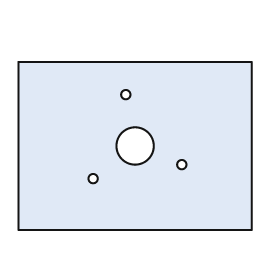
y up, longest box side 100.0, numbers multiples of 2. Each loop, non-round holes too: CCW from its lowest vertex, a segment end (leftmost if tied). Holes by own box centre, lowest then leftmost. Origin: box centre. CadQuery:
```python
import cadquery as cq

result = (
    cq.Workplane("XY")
    .moveTo(-50.0, -36.0)
    .lineTo(50.0, -36.0)
    .lineTo(50.0, 36.0)
    .lineTo(-50.0, 36.0)
    .close()
    .moveTo(-18.0, -14.0)
    .circle(2.0)
    .moveTo(20.0, -8.0)
    .circle(2.0)
    .moveTo(0.0, 0.0)
    .circle(8.0)
    .moveTo(-4.0, 22.0)
    .circle(2.0)
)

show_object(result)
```